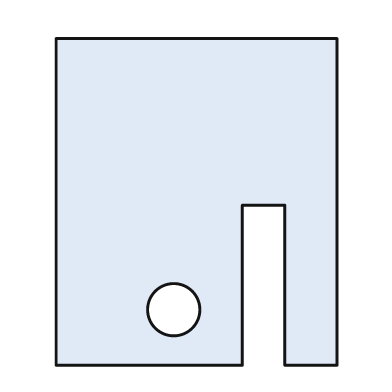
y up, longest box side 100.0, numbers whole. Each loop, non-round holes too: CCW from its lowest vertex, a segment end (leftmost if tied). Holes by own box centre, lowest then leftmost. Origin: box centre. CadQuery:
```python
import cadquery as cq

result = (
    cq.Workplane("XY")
    .moveTo(-43.0, -50.0)
    .lineTo(14.0, -50.0)
    .lineTo(14.0, -1.0)
    .lineTo(27.0, -1.0)
    .lineTo(27.0, -50.0)
    .lineTo(43.0, -50.0)
    .lineTo(43.0, 50.0)
    .lineTo(-43.0, 50.0)
    .close()
    .moveTo(-7.0, -33.0)
    .circle(8.0)
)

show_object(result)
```